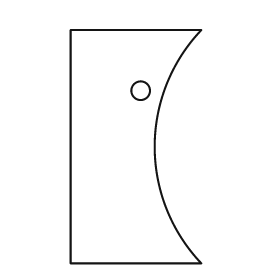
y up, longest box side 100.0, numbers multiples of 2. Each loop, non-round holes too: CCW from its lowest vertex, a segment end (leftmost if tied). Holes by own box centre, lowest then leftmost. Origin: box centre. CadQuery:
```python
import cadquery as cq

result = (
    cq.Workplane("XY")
    .moveTo(-28.0, -50.0)
    .lineTo(28.0, -50.0)
    .threePointArc((8.0, 0.0), (28.0, 50.0))
    .lineTo(-28.0, 50.0)
    .close()
    .moveTo(2.0, 24.0)
    .circle(4.0)
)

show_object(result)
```